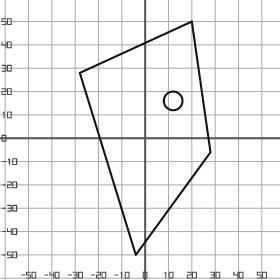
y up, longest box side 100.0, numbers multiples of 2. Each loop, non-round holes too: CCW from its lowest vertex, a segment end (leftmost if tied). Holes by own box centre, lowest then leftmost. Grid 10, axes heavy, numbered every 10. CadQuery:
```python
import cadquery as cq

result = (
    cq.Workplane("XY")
    .moveTo(-4.0, -50.0)
    .lineTo(28.0, -6.0)
    .lineTo(20.0, 50.0)
    .lineTo(-28.0, 28.0)
    .close()
    .moveTo(12.0, 16.0)
    .circle(4.0)
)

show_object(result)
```